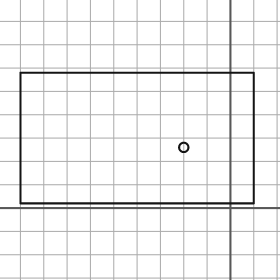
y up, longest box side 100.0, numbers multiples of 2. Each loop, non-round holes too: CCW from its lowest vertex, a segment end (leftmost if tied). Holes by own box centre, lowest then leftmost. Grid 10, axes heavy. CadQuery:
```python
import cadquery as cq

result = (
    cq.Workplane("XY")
    .moveTo(-90.0, 2.0)
    .lineTo(10.0, 2.0)
    .lineTo(10.0, 58.0)
    .lineTo(-90.0, 58.0)
    .close()
    .moveTo(-20.0, 26.0)
    .circle(2.0)
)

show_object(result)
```